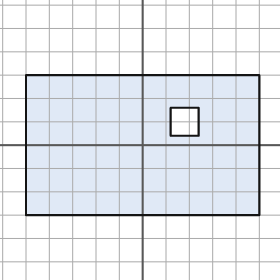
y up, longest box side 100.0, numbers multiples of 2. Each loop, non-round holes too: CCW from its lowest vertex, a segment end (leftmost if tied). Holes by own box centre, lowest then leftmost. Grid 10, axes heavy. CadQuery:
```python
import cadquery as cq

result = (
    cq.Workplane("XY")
    .moveTo(-50.0, -30.0)
    .lineTo(50.0, -30.0)
    .lineTo(50.0, 30.0)
    .lineTo(-50.0, 30.0)
    .close()
    .moveTo(12.0, 4.0)
    .lineTo(24.0, 4.0)
    .lineTo(24.0, 16.0)
    .lineTo(12.0, 16.0)
    .close()
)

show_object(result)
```